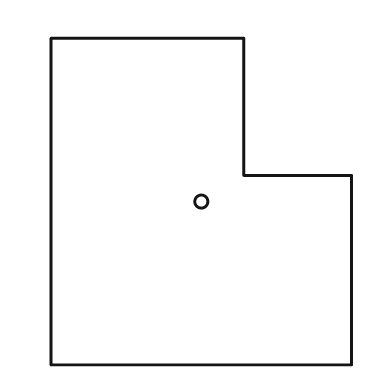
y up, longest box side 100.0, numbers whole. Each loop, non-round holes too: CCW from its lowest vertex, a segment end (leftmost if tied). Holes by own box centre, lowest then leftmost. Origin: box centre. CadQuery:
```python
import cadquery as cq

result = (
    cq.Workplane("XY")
    .moveTo(-46.0, -50.0)
    .lineTo(46.0, -50.0)
    .lineTo(46.0, 8.0)
    .lineTo(13.0, 8.0)
    .lineTo(13.0, 50.0)
    .lineTo(-46.0, 50.0)
    .close()
    .moveTo(0.0, 0.0)
    .circle(2.0)
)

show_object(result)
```